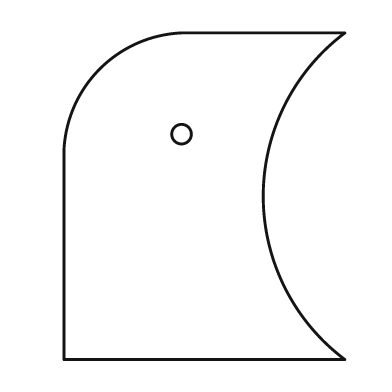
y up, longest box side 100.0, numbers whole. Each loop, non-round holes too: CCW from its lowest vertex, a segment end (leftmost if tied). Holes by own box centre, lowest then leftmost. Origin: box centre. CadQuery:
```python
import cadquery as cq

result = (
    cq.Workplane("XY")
    .moveTo(-43.0, -50.0)
    .lineTo(43.0, -50.0)
    .threePointArc((18.0, 0.0), (43.0, 50.0))
    .lineTo(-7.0, 50.0)
    .threePointArc((-32.0, 39.0), (-43.0, 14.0))
    .close()
    .moveTo(-7.0, 19.0)
    .circle(3.0)
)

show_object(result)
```